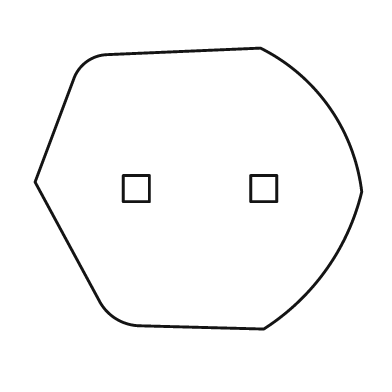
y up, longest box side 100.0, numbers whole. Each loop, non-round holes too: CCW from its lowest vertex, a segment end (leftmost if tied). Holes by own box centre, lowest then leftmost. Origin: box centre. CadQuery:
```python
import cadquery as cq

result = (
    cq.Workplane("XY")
    .moveTo(20.0, -43.0)
    .threePointArc((39.0, -25.0), (50.0, -1.0))
    .threePointArc((40.0, 25.0), (19.0, 43.0))
    .lineTo(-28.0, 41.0)
    .threePointArc((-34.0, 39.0), (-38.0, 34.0))
    .lineTo(-50.0, 2.0)
    .lineTo(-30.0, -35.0)
    .threePointArc((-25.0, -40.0), (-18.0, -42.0))
    .close()
    .moveTo(-23.0, -4.0)
    .lineTo(-15.0, -4.0)
    .lineTo(-15.0, 4.0)
    .lineTo(-23.0, 4.0)
    .close()
    .moveTo(16.0, -4.0)
    .lineTo(24.0, -4.0)
    .lineTo(24.0, 4.0)
    .lineTo(16.0, 4.0)
    .close()
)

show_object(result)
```